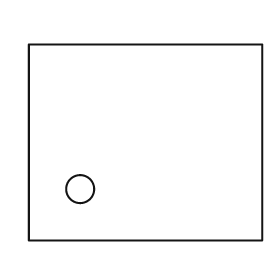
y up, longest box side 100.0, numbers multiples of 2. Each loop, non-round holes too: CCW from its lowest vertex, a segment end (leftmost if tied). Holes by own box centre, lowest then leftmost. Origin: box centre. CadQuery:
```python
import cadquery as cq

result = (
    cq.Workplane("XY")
    .moveTo(-50.0, -42.0)
    .lineTo(50.0, -42.0)
    .lineTo(50.0, 42.0)
    .lineTo(-50.0, 42.0)
    .close()
    .moveTo(-28.0, -20.0)
    .circle(6.0)
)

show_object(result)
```